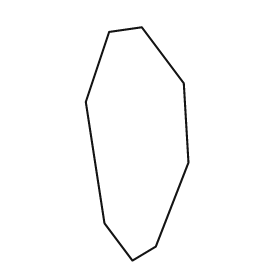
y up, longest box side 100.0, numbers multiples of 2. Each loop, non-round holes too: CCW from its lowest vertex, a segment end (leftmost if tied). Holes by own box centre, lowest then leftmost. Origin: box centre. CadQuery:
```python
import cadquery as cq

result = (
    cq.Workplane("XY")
    .moveTo(-2.0, -50.0)
    .lineTo(8.0, -44.0)
    .lineTo(22.0, -8.0)
    .lineTo(20.0, 26.0)
    .lineTo(2.0, 50.0)
    .lineTo(-12.0, 48.0)
    .lineTo(-22.0, 18.0)
    .lineTo(-14.0, -34.0)
    .close()
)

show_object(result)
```